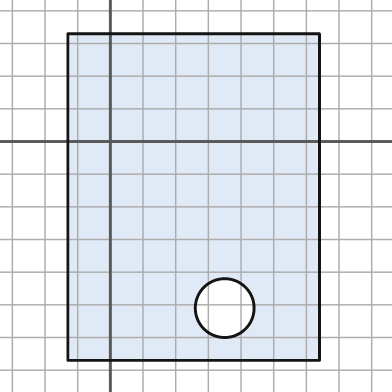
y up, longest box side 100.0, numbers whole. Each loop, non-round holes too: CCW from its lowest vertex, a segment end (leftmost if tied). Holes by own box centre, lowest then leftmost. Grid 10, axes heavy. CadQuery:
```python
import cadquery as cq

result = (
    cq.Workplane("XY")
    .moveTo(-13.0, -67.0)
    .lineTo(64.0, -67.0)
    .lineTo(64.0, 33.0)
    .lineTo(-13.0, 33.0)
    .close()
    .moveTo(35.0, -51.0)
    .circle(9.0)
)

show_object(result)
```